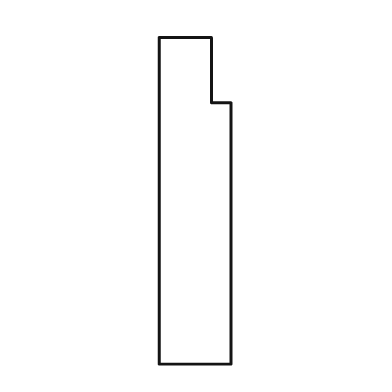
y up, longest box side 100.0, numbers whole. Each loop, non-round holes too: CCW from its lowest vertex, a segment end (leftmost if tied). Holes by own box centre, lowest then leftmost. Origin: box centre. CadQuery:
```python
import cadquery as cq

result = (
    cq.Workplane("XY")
    .moveTo(-11.0, -50.0)
    .lineTo(11.0, -50.0)
    .lineTo(11.0, 30.0)
    .lineTo(5.0, 30.0)
    .lineTo(5.0, 50.0)
    .lineTo(-11.0, 50.0)
    .close()
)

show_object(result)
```